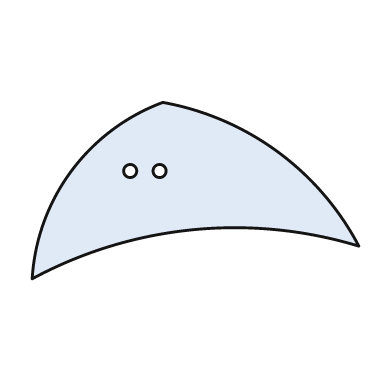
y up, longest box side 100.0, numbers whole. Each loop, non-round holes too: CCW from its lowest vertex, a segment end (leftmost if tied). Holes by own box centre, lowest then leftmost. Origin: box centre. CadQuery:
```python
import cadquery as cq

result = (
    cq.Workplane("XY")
    .moveTo(-50.0, -27.0)
    .threePointArc((-1.0, -12.0), (50.0, -17.0))
    .threePointArc((25.0, 12.0), (-10.0, 27.0))
    .threePointArc((-38.0, 6.0), (-50.0, -27.0))
    .close()
    .moveTo(-20.0, 6.0)
    .circle(2.0)
    .moveTo(-11.0, 6.0)
    .circle(2.0)
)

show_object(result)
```